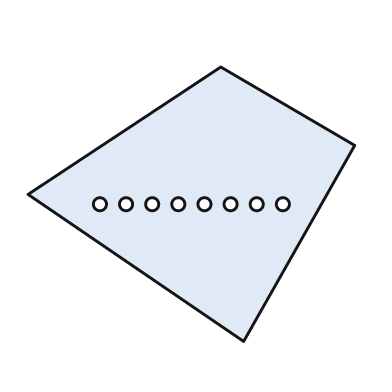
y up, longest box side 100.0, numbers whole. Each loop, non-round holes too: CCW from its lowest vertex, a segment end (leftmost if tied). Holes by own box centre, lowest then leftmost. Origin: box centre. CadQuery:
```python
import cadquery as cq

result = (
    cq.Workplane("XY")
    .moveTo(16.0, -42.0)
    .lineTo(50.0, 18.0)
    .lineTo(9.0, 42.0)
    .lineTo(-50.0, 3.0)
    .close()
    .moveTo(-28.0, 0.0)
    .circle(2.0)
    .moveTo(-20.0, 0.0)
    .circle(2.0)
    .moveTo(-12.0, 0.0)
    .circle(2.0)
    .moveTo(-4.0, 0.0)
    .circle(2.0)
    .moveTo(4.0, 0.0)
    .circle(2.0)
    .moveTo(12.0, 0.0)
    .circle(2.0)
    .moveTo(20.0, 0.0)
    .circle(2.0)
    .moveTo(28.0, 0.0)
    .circle(2.0)
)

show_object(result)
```